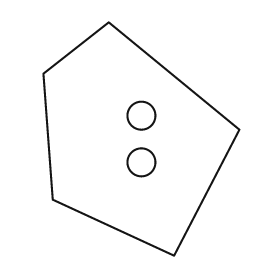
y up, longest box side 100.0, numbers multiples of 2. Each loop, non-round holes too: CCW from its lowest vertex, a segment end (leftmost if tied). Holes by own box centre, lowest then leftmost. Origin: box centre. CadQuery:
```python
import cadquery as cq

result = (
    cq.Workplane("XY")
    .moveTo(14.0, -50.0)
    .lineTo(42.0, 4.0)
    .lineTo(-14.0, 50.0)
    .lineTo(-42.0, 28.0)
    .lineTo(-38.0, -26.0)
    .close()
    .moveTo(0.0, -10.0)
    .circle(6.0)
    .moveTo(0.0, 10.0)
    .circle(6.0)
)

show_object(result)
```